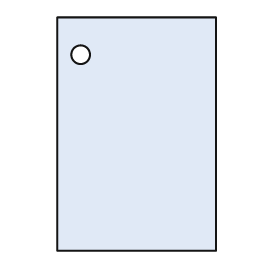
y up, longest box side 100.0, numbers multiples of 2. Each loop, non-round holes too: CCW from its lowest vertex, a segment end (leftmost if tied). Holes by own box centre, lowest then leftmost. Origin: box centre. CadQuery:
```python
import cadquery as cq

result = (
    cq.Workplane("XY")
    .moveTo(-34.0, -50.0)
    .lineTo(34.0, -50.0)
    .lineTo(34.0, 50.0)
    .lineTo(-34.0, 50.0)
    .close()
    .moveTo(-24.0, 34.0)
    .circle(4.0)
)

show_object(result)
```